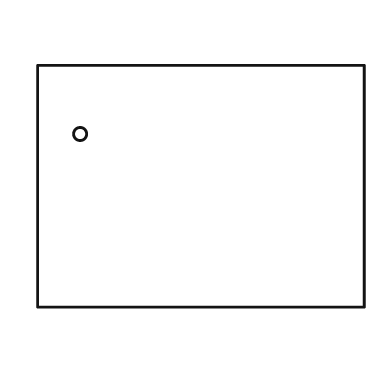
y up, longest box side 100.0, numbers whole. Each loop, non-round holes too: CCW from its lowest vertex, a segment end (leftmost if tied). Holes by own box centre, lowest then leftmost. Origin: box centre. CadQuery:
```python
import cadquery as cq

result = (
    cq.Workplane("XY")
    .moveTo(-50.0, -37.0)
    .lineTo(50.0, -37.0)
    .lineTo(50.0, 37.0)
    .lineTo(-50.0, 37.0)
    .close()
    .moveTo(-37.0, 16.0)
    .circle(2.0)
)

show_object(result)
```